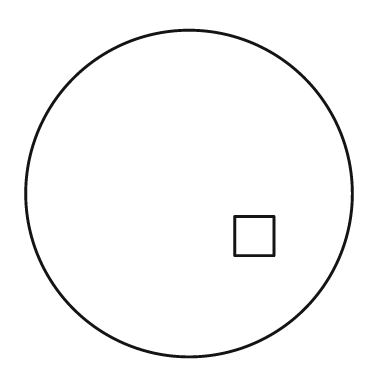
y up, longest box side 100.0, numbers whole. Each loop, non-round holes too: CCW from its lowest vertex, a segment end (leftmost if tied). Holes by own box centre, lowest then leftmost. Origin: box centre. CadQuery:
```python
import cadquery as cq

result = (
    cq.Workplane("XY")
    .moveTo(0.0, 0.0)
    .circle(50.0)
    .moveTo(14.0, -19.0)
    .lineTo(26.0, -19.0)
    .lineTo(26.0, -7.0)
    .lineTo(14.0, -7.0)
    .close()
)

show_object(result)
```